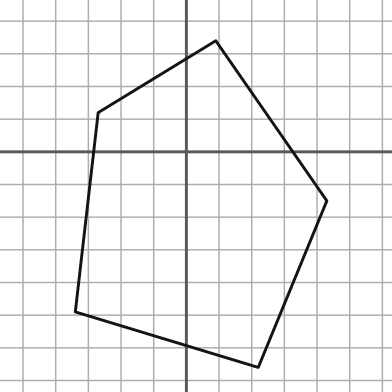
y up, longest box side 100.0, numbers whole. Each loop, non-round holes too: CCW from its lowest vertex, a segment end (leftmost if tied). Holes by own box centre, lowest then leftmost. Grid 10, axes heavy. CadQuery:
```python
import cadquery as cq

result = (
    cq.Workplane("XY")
    .moveTo(22.0, -66.0)
    .lineTo(43.0, -15.0)
    .lineTo(9.0, 34.0)
    .lineTo(-27.0, 12.0)
    .lineTo(-34.0, -49.0)
    .close()
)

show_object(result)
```